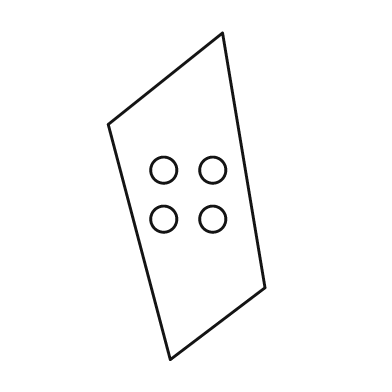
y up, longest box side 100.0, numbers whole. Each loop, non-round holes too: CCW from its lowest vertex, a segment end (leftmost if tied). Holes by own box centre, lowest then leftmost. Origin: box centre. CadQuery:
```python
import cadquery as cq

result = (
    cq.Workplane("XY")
    .moveTo(-5.0, -50.0)
    .lineTo(24.0, -28.0)
    .lineTo(11.0, 50.0)
    .lineTo(-24.0, 22.0)
    .close()
    .moveTo(-7.0, -7.0)
    .circle(4.0)
    .moveTo(8.0, -7.0)
    .circle(4.0)
    .moveTo(-7.0, 8.0)
    .circle(4.0)
    .moveTo(8.0, 8.0)
    .circle(4.0)
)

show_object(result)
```